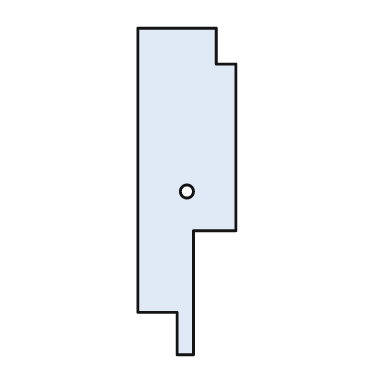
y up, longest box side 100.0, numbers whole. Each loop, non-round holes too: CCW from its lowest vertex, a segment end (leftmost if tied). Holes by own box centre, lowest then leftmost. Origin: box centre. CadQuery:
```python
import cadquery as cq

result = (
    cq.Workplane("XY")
    .moveTo(-3.0, -50.0)
    .lineTo(2.0, -50.0)
    .lineTo(2.0, -12.0)
    .lineTo(15.0, -12.0)
    .lineTo(15.0, 39.0)
    .lineTo(9.0, 39.0)
    .lineTo(9.0, 50.0)
    .lineTo(-15.0, 50.0)
    .lineTo(-15.0, -37.0)
    .lineTo(-3.0, -37.0)
    .close()
    .moveTo(0.0, 0.0)
    .circle(2.0)
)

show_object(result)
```